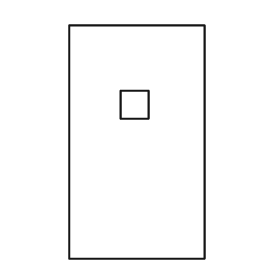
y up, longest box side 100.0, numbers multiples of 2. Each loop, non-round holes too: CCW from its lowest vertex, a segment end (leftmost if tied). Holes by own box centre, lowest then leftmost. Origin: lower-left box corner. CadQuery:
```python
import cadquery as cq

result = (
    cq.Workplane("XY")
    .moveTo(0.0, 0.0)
    .lineTo(58.0, 0.0)
    .lineTo(58.0, 100.0)
    .lineTo(0.0, 100.0)
    .close()
    .moveTo(22.0, 60.0)
    .lineTo(34.0, 60.0)
    .lineTo(34.0, 72.0)
    .lineTo(22.0, 72.0)
    .close()
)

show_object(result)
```